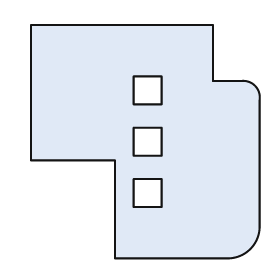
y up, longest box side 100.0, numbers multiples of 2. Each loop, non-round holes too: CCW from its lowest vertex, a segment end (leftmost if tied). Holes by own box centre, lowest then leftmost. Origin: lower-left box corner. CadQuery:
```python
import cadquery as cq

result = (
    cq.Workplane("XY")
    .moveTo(36.0, 0.0)
    .lineTo(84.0, 0.0)
    .threePointArc((94.0, 4.0), (98.0, 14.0))
    .lineTo(98.0, 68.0)
    .threePointArc((96.0, 74.0), (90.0, 76.0))
    .lineTo(78.0, 76.0)
    .lineTo(78.0, 100.0)
    .lineTo(0.0, 100.0)
    .lineTo(0.0, 42.0)
    .lineTo(36.0, 42.0)
    .close()
    .moveTo(44.0, 22.0)
    .lineTo(56.0, 22.0)
    .lineTo(56.0, 34.0)
    .lineTo(44.0, 34.0)
    .close()
    .moveTo(44.0, 44.0)
    .lineTo(56.0, 44.0)
    .lineTo(56.0, 56.0)
    .lineTo(44.0, 56.0)
    .close()
    .moveTo(44.0, 66.0)
    .lineTo(56.0, 66.0)
    .lineTo(56.0, 78.0)
    .lineTo(44.0, 78.0)
    .close()
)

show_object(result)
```